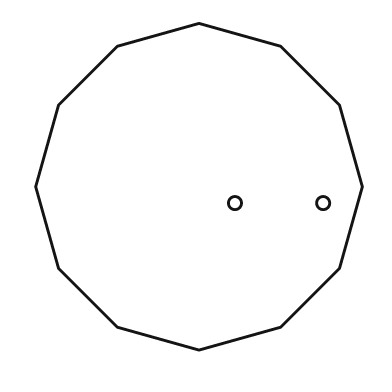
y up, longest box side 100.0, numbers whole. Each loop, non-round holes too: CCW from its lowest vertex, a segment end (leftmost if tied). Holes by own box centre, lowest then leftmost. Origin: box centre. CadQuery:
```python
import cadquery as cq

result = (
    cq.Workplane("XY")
    .moveTo(0.0, -50.0)
    .lineTo(25.0, -43.0)
    .lineTo(43.0, -25.0)
    .lineTo(50.0, 0.0)
    .lineTo(43.0, 25.0)
    .lineTo(25.0, 43.0)
    .lineTo(0.0, 50.0)
    .lineTo(-25.0, 43.0)
    .lineTo(-43.0, 25.0)
    .lineTo(-50.0, 0.0)
    .lineTo(-43.0, -25.0)
    .lineTo(-25.0, -43.0)
    .close()
    .moveTo(11.0, -5.0)
    .circle(2.0)
    .moveTo(38.0, -5.0)
    .circle(2.0)
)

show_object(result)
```